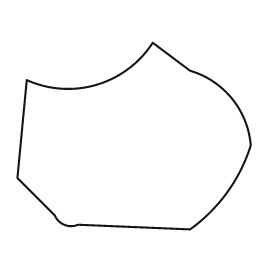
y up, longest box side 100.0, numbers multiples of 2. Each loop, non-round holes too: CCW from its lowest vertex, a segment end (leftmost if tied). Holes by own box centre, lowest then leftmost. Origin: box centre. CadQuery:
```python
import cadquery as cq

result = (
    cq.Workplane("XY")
    .moveTo(24.0, -40.0)
    .threePointArc((40.0, -24.0), (50.0, -4.0))
    .threePointArc((42.0, 16.0), (24.0, 28.0))
    .lineTo(8.0, 40.0)
    .threePointArc((-16.0, 22.0), (-46.0, 24.0))
    .lineTo(-50.0, -18.0)
    .lineTo(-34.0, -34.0)
    .threePointArc((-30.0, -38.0), (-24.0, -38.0))
    .close()
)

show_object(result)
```